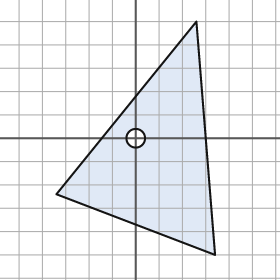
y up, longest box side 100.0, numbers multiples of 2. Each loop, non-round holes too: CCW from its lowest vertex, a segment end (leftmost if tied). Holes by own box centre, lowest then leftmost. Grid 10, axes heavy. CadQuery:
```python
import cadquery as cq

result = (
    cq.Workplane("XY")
    .moveTo(34.0, -50.0)
    .lineTo(26.0, 50.0)
    .lineTo(-34.0, -24.0)
    .close()
    .moveTo(0.0, 0.0)
    .circle(4.0)
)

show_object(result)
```